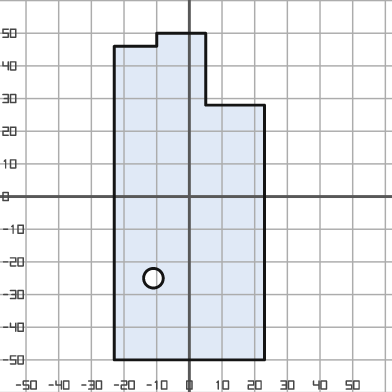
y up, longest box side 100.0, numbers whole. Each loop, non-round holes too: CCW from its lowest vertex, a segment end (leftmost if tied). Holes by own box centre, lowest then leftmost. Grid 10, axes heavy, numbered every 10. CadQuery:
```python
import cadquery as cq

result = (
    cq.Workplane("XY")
    .moveTo(-23.0, -50.0)
    .lineTo(23.0, -50.0)
    .lineTo(23.0, 28.0)
    .lineTo(5.0, 28.0)
    .lineTo(5.0, 50.0)
    .lineTo(-10.0, 50.0)
    .lineTo(-10.0, 46.0)
    .lineTo(-23.0, 46.0)
    .close()
    .moveTo(-11.0, -25.0)
    .circle(3.0)
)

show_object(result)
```